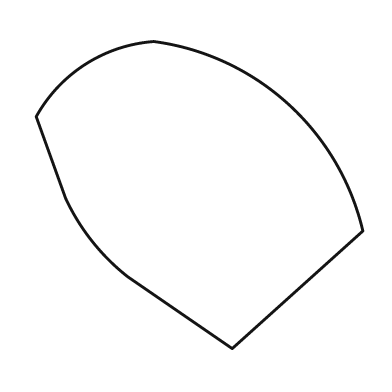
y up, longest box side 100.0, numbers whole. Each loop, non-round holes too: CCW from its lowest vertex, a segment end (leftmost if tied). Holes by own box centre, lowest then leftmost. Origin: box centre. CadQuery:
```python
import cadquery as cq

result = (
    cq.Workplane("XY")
    .moveTo(10.0, -47.0)
    .lineTo(50.0, -11.0)
    .threePointArc((27.0, 28.0), (-14.0, 47.0))
    .threePointArc((-35.0, 40.0), (-50.0, 24.0))
    .lineTo(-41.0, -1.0)
    .threePointArc((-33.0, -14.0), (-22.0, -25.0))
    .close()
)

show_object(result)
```